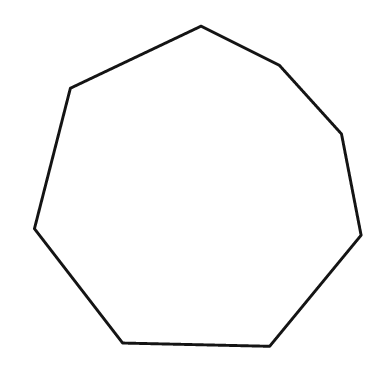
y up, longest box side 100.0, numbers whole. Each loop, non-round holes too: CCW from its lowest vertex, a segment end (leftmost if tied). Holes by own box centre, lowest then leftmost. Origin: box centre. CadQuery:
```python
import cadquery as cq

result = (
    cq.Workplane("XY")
    .moveTo(22.0, -49.0)
    .lineTo(50.0, -15.0)
    .lineTo(44.0, 16.0)
    .lineTo(25.0, 37.0)
    .lineTo(1.0, 49.0)
    .lineTo(-39.0, 30.0)
    .lineTo(-50.0, -13.0)
    .lineTo(-23.0, -48.0)
    .close()
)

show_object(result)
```